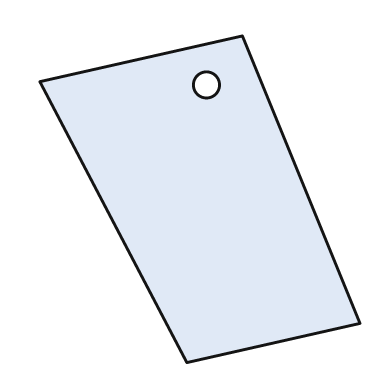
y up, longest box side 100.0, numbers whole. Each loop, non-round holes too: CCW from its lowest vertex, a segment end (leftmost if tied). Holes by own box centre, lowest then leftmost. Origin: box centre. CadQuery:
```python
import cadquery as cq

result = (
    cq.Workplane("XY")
    .moveTo(-4.0, -50.0)
    .lineTo(49.0, -38.0)
    .lineTo(13.0, 50.0)
    .lineTo(-49.0, 36.0)
    .close()
    .moveTo(2.0, 35.0)
    .circle(4.0)
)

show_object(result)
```